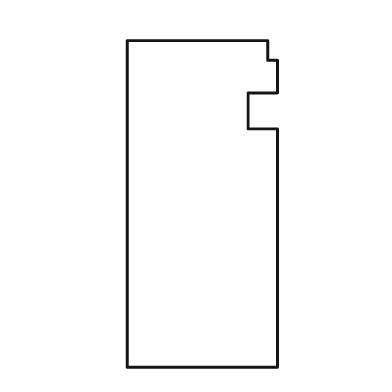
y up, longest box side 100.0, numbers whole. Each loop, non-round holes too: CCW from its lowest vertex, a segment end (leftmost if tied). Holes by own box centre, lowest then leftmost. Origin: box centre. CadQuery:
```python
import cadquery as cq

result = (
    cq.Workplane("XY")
    .moveTo(-23.0, -50.0)
    .lineTo(23.0, -50.0)
    .lineTo(23.0, 23.0)
    .lineTo(14.0, 23.0)
    .lineTo(14.0, 34.0)
    .lineTo(23.0, 34.0)
    .lineTo(23.0, 44.0)
    .lineTo(20.0, 44.0)
    .lineTo(20.0, 50.0)
    .lineTo(-23.0, 50.0)
    .close()
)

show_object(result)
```